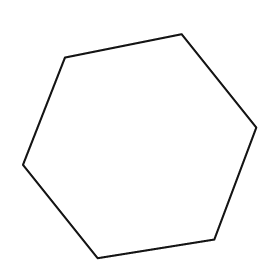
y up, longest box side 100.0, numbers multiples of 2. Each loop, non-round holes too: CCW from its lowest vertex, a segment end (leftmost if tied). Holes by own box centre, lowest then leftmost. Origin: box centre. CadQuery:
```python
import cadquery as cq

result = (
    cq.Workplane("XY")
    .moveTo(-18.0, -48.0)
    .lineTo(32.0, -40.0)
    .lineTo(50.0, 8.0)
    .lineTo(18.0, 48.0)
    .lineTo(-32.0, 38.0)
    .lineTo(-50.0, -8.0)
    .close()
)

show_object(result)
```